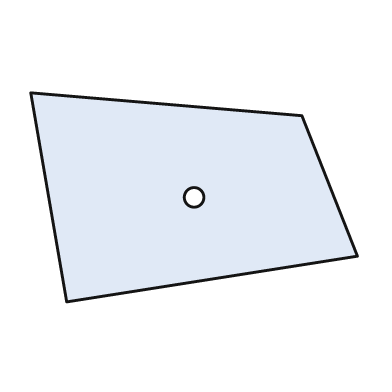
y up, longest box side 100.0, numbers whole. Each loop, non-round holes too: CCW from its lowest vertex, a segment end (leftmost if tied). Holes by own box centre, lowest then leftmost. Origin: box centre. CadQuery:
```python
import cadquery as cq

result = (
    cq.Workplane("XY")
    .moveTo(-39.0, -32.0)
    .lineTo(50.0, -18.0)
    .lineTo(33.0, 25.0)
    .lineTo(-50.0, 32.0)
    .close()
    .moveTo(0.0, 0.0)
    .circle(3.0)
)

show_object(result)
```